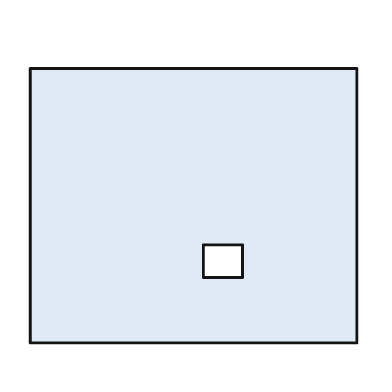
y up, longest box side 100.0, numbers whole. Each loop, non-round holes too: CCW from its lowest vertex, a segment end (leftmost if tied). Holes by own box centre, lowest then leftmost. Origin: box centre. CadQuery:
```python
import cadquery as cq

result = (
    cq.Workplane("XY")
    .moveTo(-50.0, -42.0)
    .lineTo(50.0, -42.0)
    .lineTo(50.0, 42.0)
    .lineTo(-50.0, 42.0)
    .close()
    .moveTo(3.0, -22.0)
    .lineTo(15.0, -22.0)
    .lineTo(15.0, -12.0)
    .lineTo(3.0, -12.0)
    .close()
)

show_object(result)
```